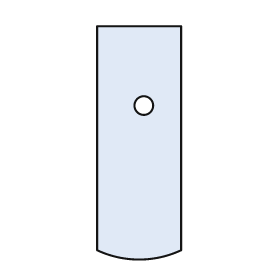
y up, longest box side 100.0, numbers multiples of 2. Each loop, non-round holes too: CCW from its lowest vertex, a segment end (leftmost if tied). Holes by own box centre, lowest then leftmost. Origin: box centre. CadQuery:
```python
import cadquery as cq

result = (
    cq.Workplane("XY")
    .moveTo(-18.0, -46.0)
    .threePointArc((0.0, -50.0), (18.0, -46.0))
    .lineTo(18.0, 50.0)
    .lineTo(-18.0, 50.0)
    .close()
    .moveTo(2.0, 16.0)
    .circle(4.0)
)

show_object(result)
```